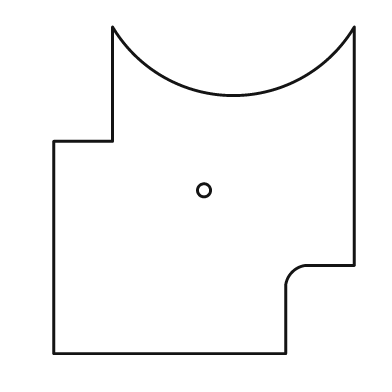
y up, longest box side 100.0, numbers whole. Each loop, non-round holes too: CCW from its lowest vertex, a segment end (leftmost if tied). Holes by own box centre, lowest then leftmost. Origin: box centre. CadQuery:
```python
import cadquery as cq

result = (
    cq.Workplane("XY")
    .moveTo(-46.0, -50.0)
    .lineTo(25.0, -50.0)
    .lineTo(25.0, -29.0)
    .threePointArc((27.0, -25.0), (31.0, -23.0))
    .lineTo(46.0, -23.0)
    .lineTo(46.0, 50.0)
    .threePointArc((9.0, 29.0), (-28.0, 50.0))
    .lineTo(-28.0, 15.0)
    .lineTo(-46.0, 15.0)
    .close()
    .moveTo(0.0, 0.0)
    .circle(2.0)
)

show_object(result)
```